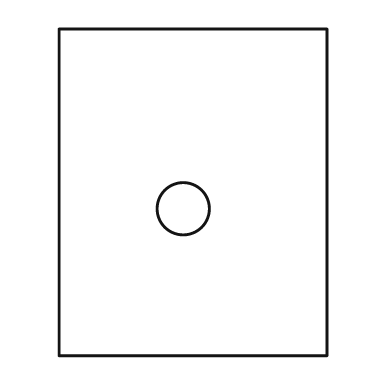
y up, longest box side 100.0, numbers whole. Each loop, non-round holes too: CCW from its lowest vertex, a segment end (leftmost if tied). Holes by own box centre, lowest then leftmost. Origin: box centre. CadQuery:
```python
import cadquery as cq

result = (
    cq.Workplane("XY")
    .moveTo(-41.0, -50.0)
    .lineTo(41.0, -50.0)
    .lineTo(41.0, 50.0)
    .lineTo(-41.0, 50.0)
    .close()
    .moveTo(-3.0, -5.0)
    .circle(8.0)
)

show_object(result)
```